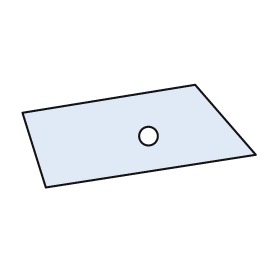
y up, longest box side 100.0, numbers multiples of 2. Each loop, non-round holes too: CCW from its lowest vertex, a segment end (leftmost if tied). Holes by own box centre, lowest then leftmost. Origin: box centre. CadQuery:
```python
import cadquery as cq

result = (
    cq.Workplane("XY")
    .moveTo(-40.0, -22.0)
    .lineTo(50.0, -8.0)
    .lineTo(24.0, 22.0)
    .lineTo(-50.0, 10.0)
    .close()
    .moveTo(4.0, 0.0)
    .circle(4.0)
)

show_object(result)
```